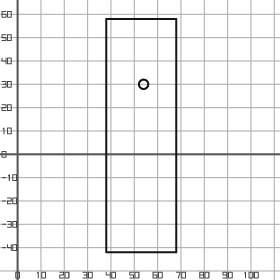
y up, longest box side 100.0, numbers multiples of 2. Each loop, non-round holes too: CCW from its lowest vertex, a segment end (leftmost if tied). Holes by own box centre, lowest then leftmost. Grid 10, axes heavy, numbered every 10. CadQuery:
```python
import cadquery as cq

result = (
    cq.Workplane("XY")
    .moveTo(38.0, -42.0)
    .lineTo(68.0, -42.0)
    .lineTo(68.0, 58.0)
    .lineTo(38.0, 58.0)
    .close()
    .moveTo(54.0, 30.0)
    .circle(2.0)
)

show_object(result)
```